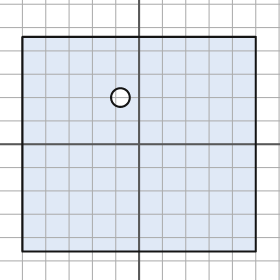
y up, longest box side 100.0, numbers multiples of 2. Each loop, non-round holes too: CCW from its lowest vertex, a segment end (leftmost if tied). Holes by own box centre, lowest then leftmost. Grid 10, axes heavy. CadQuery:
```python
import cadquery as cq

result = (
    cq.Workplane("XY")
    .moveTo(-50.0, -46.0)
    .lineTo(50.0, -46.0)
    .lineTo(50.0, 46.0)
    .lineTo(-50.0, 46.0)
    .close()
    .moveTo(-8.0, 20.0)
    .circle(4.0)
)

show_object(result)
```